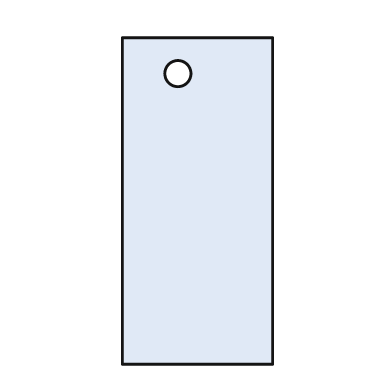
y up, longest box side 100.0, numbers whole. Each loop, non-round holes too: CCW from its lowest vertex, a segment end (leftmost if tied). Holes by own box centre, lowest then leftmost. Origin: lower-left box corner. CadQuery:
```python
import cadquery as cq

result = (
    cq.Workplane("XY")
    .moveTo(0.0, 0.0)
    .lineTo(46.0, 0.0)
    .lineTo(46.0, 100.0)
    .lineTo(0.0, 100.0)
    .close()
    .moveTo(17.0, 89.0)
    .circle(4.0)
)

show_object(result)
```